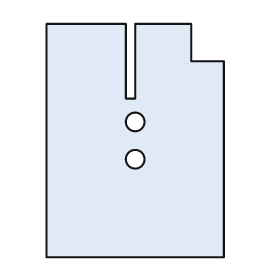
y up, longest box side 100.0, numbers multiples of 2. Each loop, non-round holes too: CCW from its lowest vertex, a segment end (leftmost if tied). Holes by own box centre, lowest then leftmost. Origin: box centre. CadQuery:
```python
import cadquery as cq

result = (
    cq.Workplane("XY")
    .moveTo(-38.0, -50.0)
    .lineTo(38.0, -50.0)
    .lineTo(38.0, 34.0)
    .lineTo(24.0, 34.0)
    .lineTo(24.0, 50.0)
    .lineTo(0.0, 50.0)
    .lineTo(0.0, 18.0)
    .lineTo(-4.0, 18.0)
    .lineTo(-4.0, 50.0)
    .lineTo(-38.0, 50.0)
    .close()
    .moveTo(0.0, -8.0)
    .circle(4.0)
    .moveTo(0.0, 8.0)
    .circle(4.0)
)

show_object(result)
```